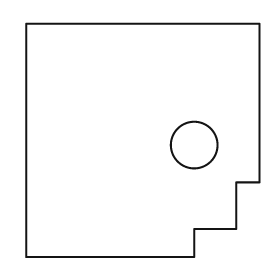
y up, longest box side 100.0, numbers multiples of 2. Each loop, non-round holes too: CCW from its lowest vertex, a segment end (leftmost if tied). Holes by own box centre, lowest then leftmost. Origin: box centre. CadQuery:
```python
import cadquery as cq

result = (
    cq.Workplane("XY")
    .moveTo(-50.0, -50.0)
    .lineTo(22.0, -50.0)
    .lineTo(22.0, -38.0)
    .lineTo(40.0, -38.0)
    .lineTo(40.0, -18.0)
    .lineTo(50.0, -18.0)
    .lineTo(50.0, 50.0)
    .lineTo(-50.0, 50.0)
    .close()
    .moveTo(22.0, -2.0)
    .circle(10.0)
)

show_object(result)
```